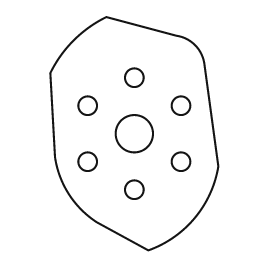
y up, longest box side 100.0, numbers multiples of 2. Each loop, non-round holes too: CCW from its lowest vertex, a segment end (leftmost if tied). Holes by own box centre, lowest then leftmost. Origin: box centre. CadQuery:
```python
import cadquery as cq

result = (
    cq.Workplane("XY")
    .moveTo(6.0, -50.0)
    .threePointArc((26.0, -36.0), (36.0, -14.0))
    .lineTo(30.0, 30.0)
    .threePointArc((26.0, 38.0), (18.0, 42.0))
    .lineTo(-12.0, 50.0)
    .threePointArc((-26.0, 40.0), (-36.0, 26.0))
    .lineTo(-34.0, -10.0)
    .threePointArc((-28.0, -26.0), (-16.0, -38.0))
    .close()
    .moveTo(0.0, -24.0)
    .circle(4.0)
    .moveTo(-20.0, -12.0)
    .circle(4.0)
    .moveTo(20.0, -12.0)
    .circle(4.0)
    .moveTo(0.0, 0.0)
    .circle(8.0)
    .moveTo(-20.0, 12.0)
    .circle(4.0)
    .moveTo(20.0, 12.0)
    .circle(4.0)
    .moveTo(0.0, 24.0)
    .circle(4.0)
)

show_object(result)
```